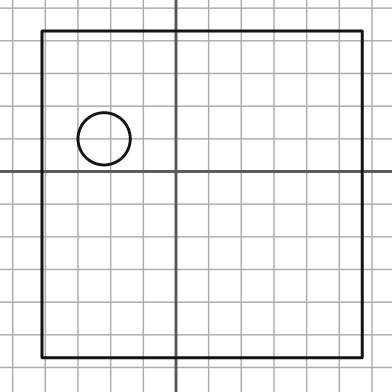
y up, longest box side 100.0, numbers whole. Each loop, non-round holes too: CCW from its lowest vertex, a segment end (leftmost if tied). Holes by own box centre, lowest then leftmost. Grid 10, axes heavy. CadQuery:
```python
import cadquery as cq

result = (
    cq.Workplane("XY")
    .moveTo(-41.0, -57.0)
    .lineTo(57.0, -57.0)
    .lineTo(57.0, 43.0)
    .lineTo(-41.0, 43.0)
    .close()
    .moveTo(-22.0, 10.0)
    .circle(8.0)
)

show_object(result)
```